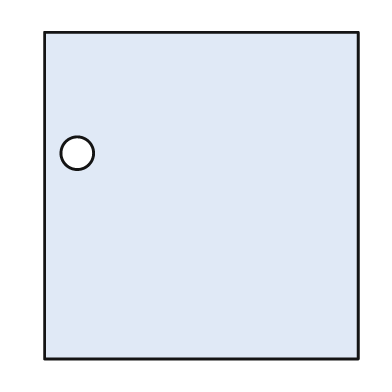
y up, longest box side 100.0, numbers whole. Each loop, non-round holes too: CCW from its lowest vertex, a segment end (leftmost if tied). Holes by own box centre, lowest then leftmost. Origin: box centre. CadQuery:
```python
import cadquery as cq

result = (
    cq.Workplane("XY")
    .moveTo(-48.0, -50.0)
    .lineTo(48.0, -50.0)
    .lineTo(48.0, 50.0)
    .lineTo(-48.0, 50.0)
    .close()
    .moveTo(-38.0, 13.0)
    .circle(5.0)
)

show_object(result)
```